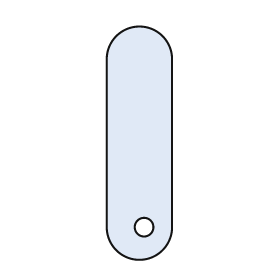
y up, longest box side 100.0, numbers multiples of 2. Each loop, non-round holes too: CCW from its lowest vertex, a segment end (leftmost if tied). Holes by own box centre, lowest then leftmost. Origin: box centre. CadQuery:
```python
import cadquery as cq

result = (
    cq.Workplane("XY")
    .moveTo(-14.0, -36.0)
    .threePointArc((0.0, -50.0), (14.0, -36.0))
    .lineTo(14.0, 36.0)
    .threePointArc((0.0, 50.0), (-14.0, 36.0))
    .close()
    .moveTo(2.0, -36.0)
    .circle(4.0)
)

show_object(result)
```